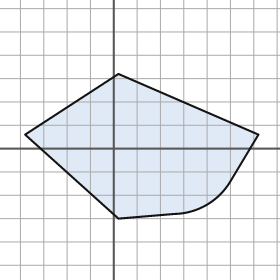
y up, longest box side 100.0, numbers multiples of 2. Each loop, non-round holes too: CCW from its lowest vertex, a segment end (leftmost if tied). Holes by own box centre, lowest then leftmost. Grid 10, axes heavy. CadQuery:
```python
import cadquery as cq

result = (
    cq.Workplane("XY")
    .moveTo(2.0, -30.0)
    .lineTo(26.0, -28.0)
    .threePointArc((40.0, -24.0), (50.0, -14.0))
    .lineTo(62.0, 6.0)
    .lineTo(2.0, 32.0)
    .lineTo(-38.0, 6.0)
    .close()
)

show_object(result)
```